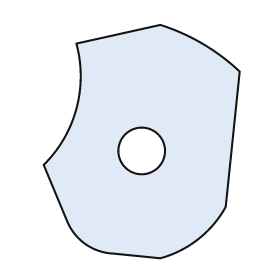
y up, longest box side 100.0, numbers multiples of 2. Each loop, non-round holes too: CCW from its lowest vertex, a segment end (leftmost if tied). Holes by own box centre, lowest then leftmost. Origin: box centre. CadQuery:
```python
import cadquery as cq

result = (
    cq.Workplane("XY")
    .moveTo(8.0, -50.0)
    .threePointArc((24.0, -42.0), (36.0, -28.0))
    .lineTo(42.0, 30.0)
    .threePointArc((26.0, 42.0), (8.0, 50.0))
    .lineTo(-28.0, 42.0)
    .threePointArc((-28.0, 14.0), (-42.0, -10.0))
    .lineTo(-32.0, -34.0)
    .threePointArc((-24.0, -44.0), (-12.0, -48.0))
    .close()
    .moveTo(0.0, -4.0)
    .circle(10.0)
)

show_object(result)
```